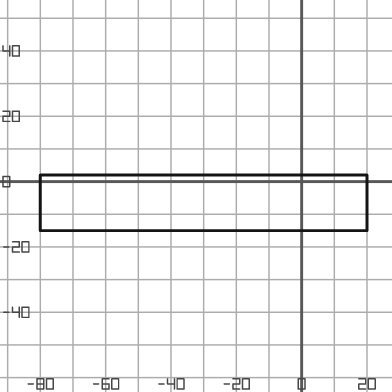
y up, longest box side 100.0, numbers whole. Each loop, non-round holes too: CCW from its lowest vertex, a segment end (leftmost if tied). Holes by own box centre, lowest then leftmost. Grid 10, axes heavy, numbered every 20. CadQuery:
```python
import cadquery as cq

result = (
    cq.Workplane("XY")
    .moveTo(-80.0, -15.0)
    .lineTo(20.0, -15.0)
    .lineTo(20.0, 2.0)
    .lineTo(-80.0, 2.0)
    .close()
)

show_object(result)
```